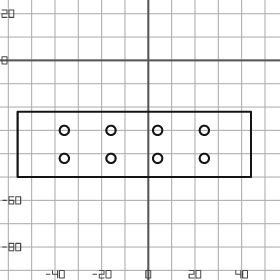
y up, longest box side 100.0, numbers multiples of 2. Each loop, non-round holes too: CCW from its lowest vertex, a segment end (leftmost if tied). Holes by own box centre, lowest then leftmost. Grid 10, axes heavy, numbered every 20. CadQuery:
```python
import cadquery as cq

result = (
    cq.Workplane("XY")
    .moveTo(-56.0, -50.0)
    .lineTo(44.0, -50.0)
    .lineTo(44.0, -22.0)
    .lineTo(-56.0, -22.0)
    .close()
    .moveTo(-36.0, -42.0)
    .circle(2.0)
    .moveTo(-16.0, -42.0)
    .circle(2.0)
    .moveTo(4.0, -42.0)
    .circle(2.0)
    .moveTo(24.0, -42.0)
    .circle(2.0)
    .moveTo(-36.0, -30.0)
    .circle(2.0)
    .moveTo(-16.0, -30.0)
    .circle(2.0)
    .moveTo(4.0, -30.0)
    .circle(2.0)
    .moveTo(24.0, -30.0)
    .circle(2.0)
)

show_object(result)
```